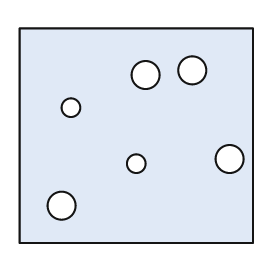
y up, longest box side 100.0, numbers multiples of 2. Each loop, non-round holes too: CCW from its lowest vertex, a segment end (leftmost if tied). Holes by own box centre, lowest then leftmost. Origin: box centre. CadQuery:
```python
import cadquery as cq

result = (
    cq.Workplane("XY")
    .moveTo(-50.0, -46.0)
    .lineTo(50.0, -46.0)
    .lineTo(50.0, 46.0)
    .lineTo(-50.0, 46.0)
    .close()
    .moveTo(-32.0, -30.0)
    .circle(6.0)
    .moveTo(0.0, -12.0)
    .circle(4.0)
    .moveTo(40.0, -10.0)
    .circle(6.0)
    .moveTo(-28.0, 12.0)
    .circle(4.0)
    .moveTo(4.0, 26.0)
    .circle(6.0)
    .moveTo(24.0, 28.0)
    .circle(6.0)
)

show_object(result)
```